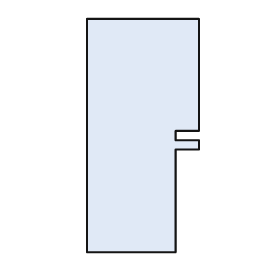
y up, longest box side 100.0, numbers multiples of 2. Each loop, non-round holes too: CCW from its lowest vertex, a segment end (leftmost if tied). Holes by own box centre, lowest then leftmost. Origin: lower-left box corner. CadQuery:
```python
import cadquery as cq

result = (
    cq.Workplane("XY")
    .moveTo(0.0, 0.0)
    .lineTo(38.0, 0.0)
    .lineTo(38.0, 44.0)
    .lineTo(48.0, 44.0)
    .lineTo(48.0, 48.0)
    .lineTo(38.0, 48.0)
    .lineTo(38.0, 52.0)
    .lineTo(48.0, 52.0)
    .lineTo(48.0, 100.0)
    .lineTo(0.0, 100.0)
    .close()
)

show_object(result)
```